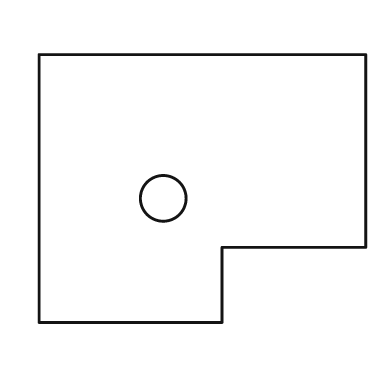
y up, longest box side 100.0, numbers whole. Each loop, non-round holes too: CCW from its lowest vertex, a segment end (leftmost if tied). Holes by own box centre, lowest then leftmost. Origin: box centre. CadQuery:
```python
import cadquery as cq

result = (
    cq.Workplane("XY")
    .moveTo(-50.0, -41.0)
    .lineTo(6.0, -41.0)
    .lineTo(6.0, -18.0)
    .lineTo(50.0, -18.0)
    .lineTo(50.0, 41.0)
    .lineTo(-50.0, 41.0)
    .close()
    .moveTo(-12.0, -3.0)
    .circle(7.0)
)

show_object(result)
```